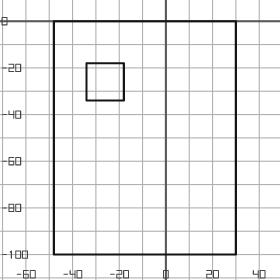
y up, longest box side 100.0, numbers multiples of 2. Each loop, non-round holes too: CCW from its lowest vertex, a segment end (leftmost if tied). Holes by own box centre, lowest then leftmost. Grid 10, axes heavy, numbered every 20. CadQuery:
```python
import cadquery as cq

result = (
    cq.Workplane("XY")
    .moveTo(-48.0, -100.0)
    .lineTo(30.0, -100.0)
    .lineTo(30.0, 0.0)
    .lineTo(-48.0, 0.0)
    .close()
    .moveTo(-34.0, -34.0)
    .lineTo(-18.0, -34.0)
    .lineTo(-18.0, -18.0)
    .lineTo(-34.0, -18.0)
    .close()
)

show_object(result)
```